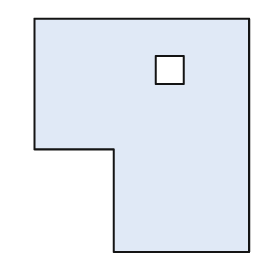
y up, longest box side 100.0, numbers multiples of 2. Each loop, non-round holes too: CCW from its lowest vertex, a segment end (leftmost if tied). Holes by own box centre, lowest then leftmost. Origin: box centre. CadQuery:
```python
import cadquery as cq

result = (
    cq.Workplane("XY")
    .moveTo(-12.0, -50.0)
    .lineTo(46.0, -50.0)
    .lineTo(46.0, 50.0)
    .lineTo(-46.0, 50.0)
    .lineTo(-46.0, -6.0)
    .lineTo(-12.0, -6.0)
    .close()
    .moveTo(6.0, 22.0)
    .lineTo(18.0, 22.0)
    .lineTo(18.0, 34.0)
    .lineTo(6.0, 34.0)
    .close()
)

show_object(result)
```